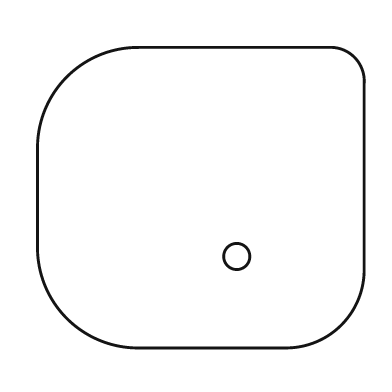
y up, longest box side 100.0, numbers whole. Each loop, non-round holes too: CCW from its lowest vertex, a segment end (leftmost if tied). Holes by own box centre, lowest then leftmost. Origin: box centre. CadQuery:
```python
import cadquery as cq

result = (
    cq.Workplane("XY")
    .moveTo(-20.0, -46.0)
    .lineTo(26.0, -46.0)
    .threePointArc((43.0, -39.0), (50.0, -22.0))
    .lineTo(50.0, 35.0)
    .threePointArc((47.0, 43.0), (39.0, 46.0))
    .lineTo(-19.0, 46.0)
    .threePointArc((-41.0, 37.0), (-50.0, 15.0))
    .lineTo(-50.0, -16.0)
    .threePointArc((-41.0, -37.0), (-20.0, -46.0))
    .close()
    .moveTo(11.0, -18.0)
    .circle(4.0)
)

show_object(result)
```